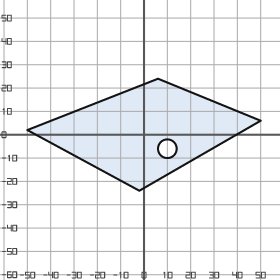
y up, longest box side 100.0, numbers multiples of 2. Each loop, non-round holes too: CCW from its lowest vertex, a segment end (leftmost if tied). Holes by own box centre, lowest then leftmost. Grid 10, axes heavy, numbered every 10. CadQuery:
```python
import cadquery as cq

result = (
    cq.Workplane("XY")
    .moveTo(-2.0, -24.0)
    .lineTo(50.0, 6.0)
    .lineTo(6.0, 24.0)
    .lineTo(-50.0, 2.0)
    .close()
    .moveTo(10.0, -6.0)
    .circle(4.0)
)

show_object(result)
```